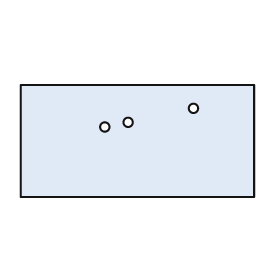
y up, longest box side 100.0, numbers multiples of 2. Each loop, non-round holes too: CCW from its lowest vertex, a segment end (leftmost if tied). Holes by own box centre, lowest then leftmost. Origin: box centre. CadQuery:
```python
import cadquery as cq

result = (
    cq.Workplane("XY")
    .moveTo(-50.0, -24.0)
    .lineTo(50.0, -24.0)
    .lineTo(50.0, 24.0)
    .lineTo(-50.0, 24.0)
    .close()
    .moveTo(-14.0, 6.0)
    .circle(2.0)
    .moveTo(-4.0, 8.0)
    .circle(2.0)
    .moveTo(24.0, 14.0)
    .circle(2.0)
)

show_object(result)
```